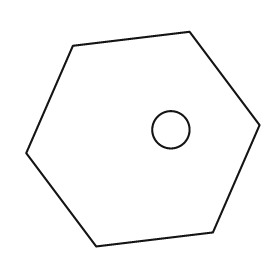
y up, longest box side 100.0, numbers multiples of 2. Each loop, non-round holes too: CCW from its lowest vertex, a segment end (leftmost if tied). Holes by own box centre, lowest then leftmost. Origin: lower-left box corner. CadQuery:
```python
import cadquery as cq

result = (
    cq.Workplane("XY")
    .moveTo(30.0, 0.0)
    .lineTo(80.0, 6.0)
    .lineTo(100.0, 52.0)
    .lineTo(70.0, 92.0)
    .lineTo(20.0, 86.0)
    .lineTo(0.0, 40.0)
    .close()
    .moveTo(62.0, 50.0)
    .circle(8.0)
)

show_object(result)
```